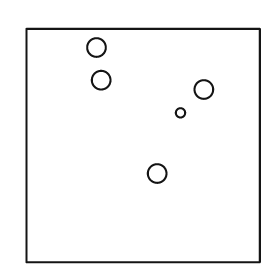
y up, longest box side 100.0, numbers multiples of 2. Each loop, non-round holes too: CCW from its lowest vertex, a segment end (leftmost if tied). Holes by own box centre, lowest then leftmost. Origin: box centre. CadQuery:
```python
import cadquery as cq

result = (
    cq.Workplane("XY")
    .moveTo(-50.0, -50.0)
    .lineTo(50.0, -50.0)
    .lineTo(50.0, 50.0)
    .lineTo(-50.0, 50.0)
    .close()
    .moveTo(6.0, -12.0)
    .circle(4.0)
    .moveTo(16.0, 14.0)
    .circle(2.0)
    .moveTo(26.0, 24.0)
    .circle(4.0)
    .moveTo(-18.0, 28.0)
    .circle(4.0)
    .moveTo(-20.0, 42.0)
    .circle(4.0)
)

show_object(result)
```